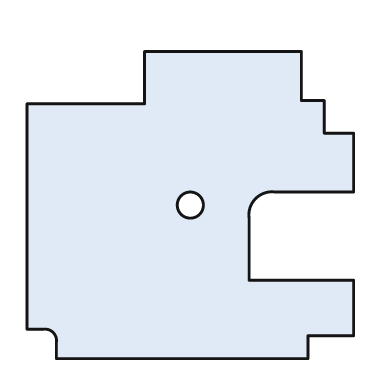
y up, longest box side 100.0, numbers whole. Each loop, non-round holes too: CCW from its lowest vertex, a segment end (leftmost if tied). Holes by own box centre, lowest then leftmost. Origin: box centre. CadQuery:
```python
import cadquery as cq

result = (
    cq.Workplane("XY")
    .moveTo(-41.0, -47.0)
    .lineTo(36.0, -47.0)
    .lineTo(36.0, -40.0)
    .lineTo(50.0, -40.0)
    .lineTo(50.0, -23.0)
    .lineTo(18.0, -23.0)
    .lineTo(18.0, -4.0)
    .threePointArc((20.0, 2.0), (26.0, 4.0))
    .lineTo(50.0, 4.0)
    .lineTo(50.0, 22.0)
    .lineTo(41.0, 22.0)
    .lineTo(41.0, 32.0)
    .lineTo(34.0, 32.0)
    .lineTo(34.0, 47.0)
    .lineTo(-14.0, 47.0)
    .lineTo(-14.0, 31.0)
    .lineTo(-50.0, 31.0)
    .lineTo(-50.0, -38.0)
    .lineTo(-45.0, -38.0)
    .threePointArc((-42.0, -39.0), (-41.0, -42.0))
    .close()
    .moveTo(0.0, 0.0)
    .circle(4.0)
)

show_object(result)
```